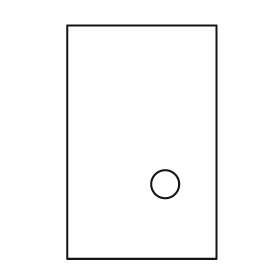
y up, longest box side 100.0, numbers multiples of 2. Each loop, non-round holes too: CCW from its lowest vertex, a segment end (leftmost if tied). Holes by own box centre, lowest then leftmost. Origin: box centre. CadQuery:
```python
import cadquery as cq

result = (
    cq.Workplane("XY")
    .moveTo(-32.0, -50.0)
    .lineTo(32.0, -50.0)
    .lineTo(32.0, 50.0)
    .lineTo(-32.0, 50.0)
    .close()
    .moveTo(10.0, -18.0)
    .circle(6.0)
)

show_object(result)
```